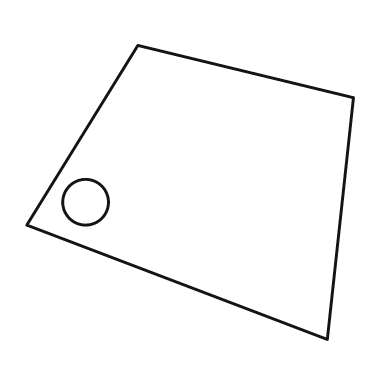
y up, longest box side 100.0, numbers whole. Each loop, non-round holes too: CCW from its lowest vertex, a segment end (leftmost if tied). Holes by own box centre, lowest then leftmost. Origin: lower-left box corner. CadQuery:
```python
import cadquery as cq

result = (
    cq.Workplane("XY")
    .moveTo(92.0, 0.0)
    .lineTo(100.0, 74.0)
    .lineTo(34.0, 90.0)
    .lineTo(0.0, 35.0)
    .close()
    .moveTo(18.0, 42.0)
    .circle(7.0)
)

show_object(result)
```